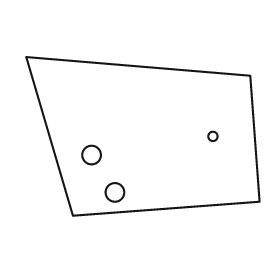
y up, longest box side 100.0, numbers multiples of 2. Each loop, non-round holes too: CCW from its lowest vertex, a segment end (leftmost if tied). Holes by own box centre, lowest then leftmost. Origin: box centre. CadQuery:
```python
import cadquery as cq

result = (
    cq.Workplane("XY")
    .moveTo(-30.0, -34.0)
    .lineTo(50.0, -28.0)
    .lineTo(46.0, 26.0)
    .lineTo(-50.0, 34.0)
    .close()
    .moveTo(-12.0, -24.0)
    .circle(4.0)
    .moveTo(-22.0, -8.0)
    .circle(4.0)
    .moveTo(30.0, 0.0)
    .circle(2.0)
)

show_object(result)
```